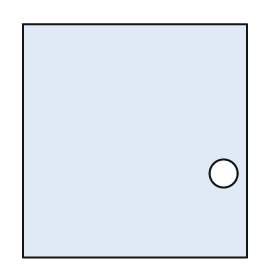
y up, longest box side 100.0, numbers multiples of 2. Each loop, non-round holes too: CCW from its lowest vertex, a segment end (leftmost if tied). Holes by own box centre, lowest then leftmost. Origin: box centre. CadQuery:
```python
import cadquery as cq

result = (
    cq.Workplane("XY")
    .moveTo(-48.0, -50.0)
    .lineTo(48.0, -50.0)
    .lineTo(48.0, 50.0)
    .lineTo(-48.0, 50.0)
    .close()
    .moveTo(38.0, -14.0)
    .circle(6.0)
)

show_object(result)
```